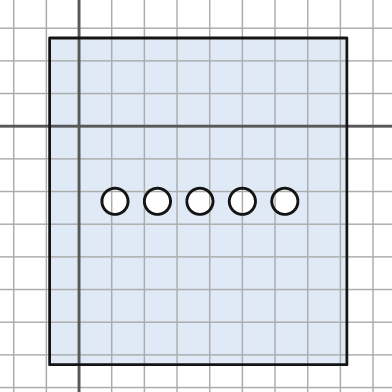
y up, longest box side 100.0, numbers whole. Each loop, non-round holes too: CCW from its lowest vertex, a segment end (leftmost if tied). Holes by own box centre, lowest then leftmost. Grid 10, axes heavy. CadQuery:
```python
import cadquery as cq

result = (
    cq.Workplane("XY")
    .moveTo(-9.0, -73.0)
    .lineTo(82.0, -73.0)
    .lineTo(82.0, 27.0)
    .lineTo(-9.0, 27.0)
    .close()
    .moveTo(11.0, -23.0)
    .circle(4.0)
    .moveTo(24.0, -23.0)
    .circle(4.0)
    .moveTo(37.0, -23.0)
    .circle(4.0)
    .moveTo(50.0, -23.0)
    .circle(4.0)
    .moveTo(63.0, -23.0)
    .circle(4.0)
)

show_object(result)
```